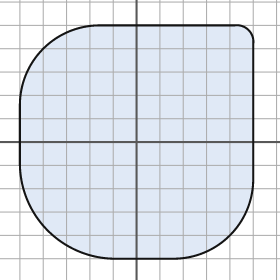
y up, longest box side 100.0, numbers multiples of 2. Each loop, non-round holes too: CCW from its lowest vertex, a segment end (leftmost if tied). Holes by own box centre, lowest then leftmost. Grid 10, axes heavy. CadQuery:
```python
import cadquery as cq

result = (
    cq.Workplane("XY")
    .moveTo(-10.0, -50.0)
    .lineTo(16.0, -50.0)
    .threePointArc((40.0, -40.0), (50.0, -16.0))
    .lineTo(50.0, 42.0)
    .threePointArc((48.0, 48.0), (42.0, 50.0))
    .lineTo(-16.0, 50.0)
    .threePointArc((-40.0, 40.0), (-50.0, 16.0))
    .lineTo(-50.0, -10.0)
    .threePointArc((-38.0, -38.0), (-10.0, -50.0))
    .close()
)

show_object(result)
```